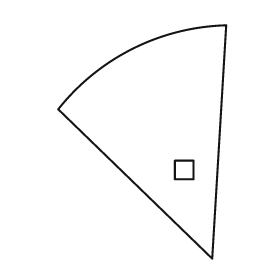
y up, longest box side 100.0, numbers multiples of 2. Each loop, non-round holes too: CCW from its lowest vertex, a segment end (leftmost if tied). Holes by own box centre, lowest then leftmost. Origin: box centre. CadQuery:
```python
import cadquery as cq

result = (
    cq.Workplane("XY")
    .moveTo(30.0, -50.0)
    .lineTo(36.0, 50.0)
    .threePointArc((-4.0, 40.0), (-36.0, 14.0))
    .close()
    .moveTo(14.0, -16.0)
    .lineTo(22.0, -16.0)
    .lineTo(22.0, -8.0)
    .lineTo(14.0, -8.0)
    .close()
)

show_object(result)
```